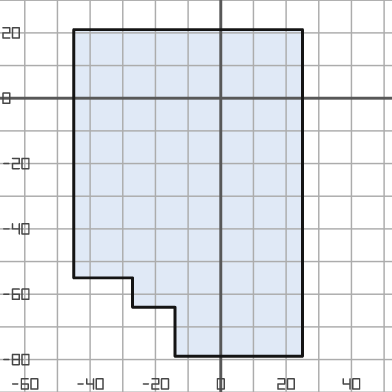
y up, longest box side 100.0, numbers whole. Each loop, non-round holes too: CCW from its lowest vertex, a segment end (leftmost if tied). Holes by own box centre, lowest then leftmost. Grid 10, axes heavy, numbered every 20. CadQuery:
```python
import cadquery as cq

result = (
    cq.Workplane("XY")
    .moveTo(-14.0, -79.0)
    .lineTo(25.0, -79.0)
    .lineTo(25.0, 21.0)
    .lineTo(-45.0, 21.0)
    .lineTo(-45.0, -55.0)
    .lineTo(-27.0, -55.0)
    .lineTo(-27.0, -64.0)
    .lineTo(-14.0, -64.0)
    .close()
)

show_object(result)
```